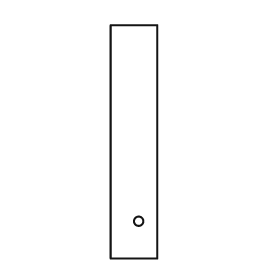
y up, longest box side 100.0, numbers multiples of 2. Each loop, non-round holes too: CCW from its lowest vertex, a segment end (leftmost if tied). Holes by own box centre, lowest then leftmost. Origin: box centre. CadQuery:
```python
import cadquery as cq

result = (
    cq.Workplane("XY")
    .moveTo(-10.0, -50.0)
    .lineTo(10.0, -50.0)
    .lineTo(10.0, 50.0)
    .lineTo(-10.0, 50.0)
    .close()
    .moveTo(2.0, -34.0)
    .circle(2.0)
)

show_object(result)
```